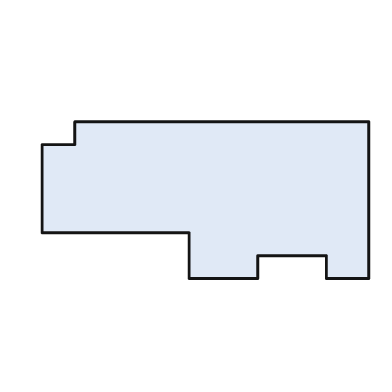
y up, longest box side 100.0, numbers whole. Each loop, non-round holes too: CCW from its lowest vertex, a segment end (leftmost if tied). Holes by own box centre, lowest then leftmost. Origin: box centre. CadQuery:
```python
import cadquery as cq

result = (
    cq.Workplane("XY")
    .moveTo(-5.0, -24.0)
    .lineTo(16.0, -24.0)
    .lineTo(16.0, -17.0)
    .lineTo(37.0, -17.0)
    .lineTo(37.0, -24.0)
    .lineTo(50.0, -24.0)
    .lineTo(50.0, 24.0)
    .lineTo(-40.0, 24.0)
    .lineTo(-40.0, 17.0)
    .lineTo(-50.0, 17.0)
    .lineTo(-50.0, -10.0)
    .lineTo(-5.0, -10.0)
    .close()
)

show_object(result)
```